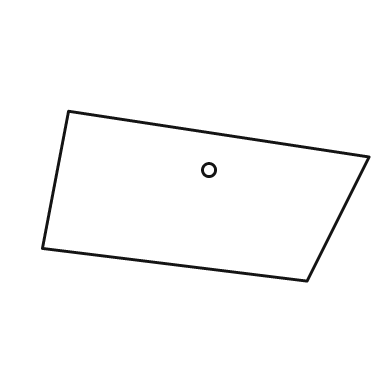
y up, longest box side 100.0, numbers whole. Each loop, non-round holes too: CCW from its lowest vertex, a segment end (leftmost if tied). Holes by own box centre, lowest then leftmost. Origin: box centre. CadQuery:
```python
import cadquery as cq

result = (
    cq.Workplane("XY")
    .moveTo(31.0, -26.0)
    .lineTo(50.0, 12.0)
    .lineTo(-42.0, 26.0)
    .lineTo(-50.0, -16.0)
    .close()
    .moveTo(1.0, 8.0)
    .circle(2.0)
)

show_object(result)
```